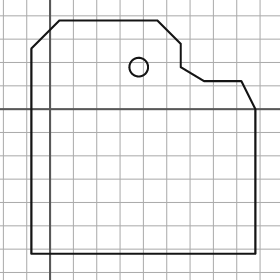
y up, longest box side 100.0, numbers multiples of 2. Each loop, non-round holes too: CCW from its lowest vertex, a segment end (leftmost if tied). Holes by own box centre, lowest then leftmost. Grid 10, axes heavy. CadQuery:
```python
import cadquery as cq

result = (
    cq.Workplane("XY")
    .moveTo(-8.0, -62.0)
    .lineTo(88.0, -62.0)
    .lineTo(88.0, 0.0)
    .lineTo(82.0, 12.0)
    .lineTo(66.0, 12.0)
    .lineTo(56.0, 18.0)
    .lineTo(56.0, 28.0)
    .lineTo(46.0, 38.0)
    .lineTo(4.0, 38.0)
    .lineTo(-8.0, 26.0)
    .close()
    .moveTo(38.0, 18.0)
    .circle(4.0)
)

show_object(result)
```